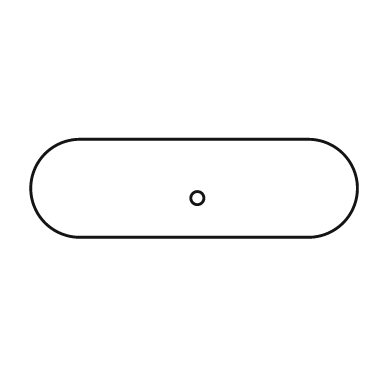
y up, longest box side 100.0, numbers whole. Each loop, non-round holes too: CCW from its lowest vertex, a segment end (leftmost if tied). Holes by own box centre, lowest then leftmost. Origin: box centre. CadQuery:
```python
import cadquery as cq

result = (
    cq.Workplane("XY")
    .moveTo(-35.0, -15.0)
    .lineTo(35.0, -15.0)
    .threePointArc((50.0, 0.0), (35.0, 15.0))
    .lineTo(-35.0, 15.0)
    .threePointArc((-50.0, 0.0), (-35.0, -15.0))
    .close()
    .moveTo(1.0, -3.0)
    .circle(2.0)
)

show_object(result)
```